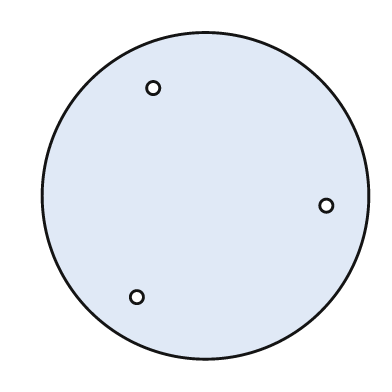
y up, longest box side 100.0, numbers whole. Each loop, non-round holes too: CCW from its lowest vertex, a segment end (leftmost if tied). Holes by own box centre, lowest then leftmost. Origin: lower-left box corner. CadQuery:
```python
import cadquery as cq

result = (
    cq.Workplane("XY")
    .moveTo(50.0, 50.0)
    .circle(50.0)
    .moveTo(29.0, 19.0)
    .circle(2.0)
    .moveTo(87.0, 47.0)
    .circle(2.0)
    .moveTo(34.0, 83.0)
    .circle(2.0)
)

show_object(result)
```